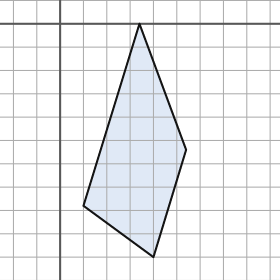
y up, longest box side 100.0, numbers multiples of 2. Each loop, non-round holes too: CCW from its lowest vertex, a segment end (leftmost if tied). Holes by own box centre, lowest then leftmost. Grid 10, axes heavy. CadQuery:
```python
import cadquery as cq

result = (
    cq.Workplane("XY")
    .moveTo(40.0, -100.0)
    .lineTo(54.0, -54.0)
    .lineTo(34.0, 0.0)
    .lineTo(10.0, -78.0)
    .close()
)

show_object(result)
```